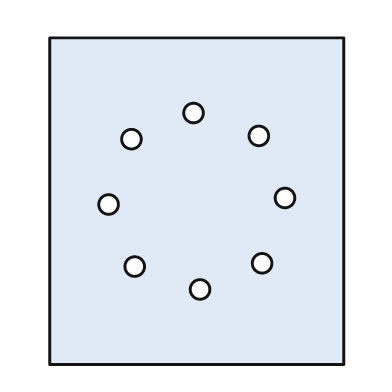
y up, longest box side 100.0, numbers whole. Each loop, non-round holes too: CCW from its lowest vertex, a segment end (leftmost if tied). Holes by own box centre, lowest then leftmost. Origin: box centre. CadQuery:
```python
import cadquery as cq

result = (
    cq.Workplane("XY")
    .moveTo(-45.0, -50.0)
    .lineTo(45.0, -50.0)
    .lineTo(45.0, 50.0)
    .lineTo(-45.0, 50.0)
    .close()
    .moveTo(1.0, -27.0)
    .circle(3.0)
    .moveTo(-19.0, -20.0)
    .circle(3.0)
    .moveTo(20.0, -19.0)
    .circle(3.0)
    .moveTo(-27.0, -1.0)
    .circle(3.0)
    .moveTo(27.0, 1.0)
    .circle(3.0)
    .moveTo(-20.0, 19.0)
    .circle(3.0)
    .moveTo(19.0, 20.0)
    .circle(3.0)
    .moveTo(-1.0, 27.0)
    .circle(3.0)
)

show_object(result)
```